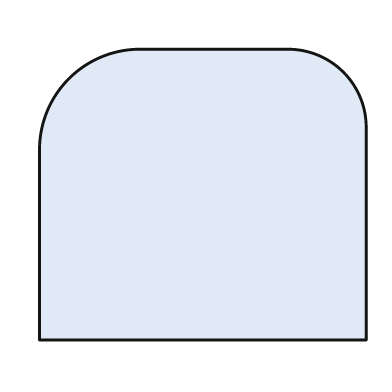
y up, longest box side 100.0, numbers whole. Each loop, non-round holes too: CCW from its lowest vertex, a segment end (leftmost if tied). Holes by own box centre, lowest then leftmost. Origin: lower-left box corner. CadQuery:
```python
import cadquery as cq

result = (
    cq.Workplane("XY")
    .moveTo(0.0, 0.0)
    .lineTo(100.0, 0.0)
    .lineTo(100.0, 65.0)
    .threePointArc((93.0, 82.0), (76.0, 89.0))
    .lineTo(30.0, 89.0)
    .threePointArc((9.0, 80.0), (0.0, 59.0))
    .close()
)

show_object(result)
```